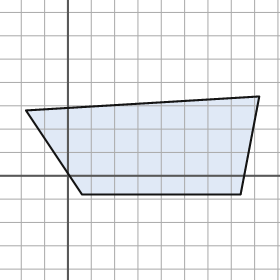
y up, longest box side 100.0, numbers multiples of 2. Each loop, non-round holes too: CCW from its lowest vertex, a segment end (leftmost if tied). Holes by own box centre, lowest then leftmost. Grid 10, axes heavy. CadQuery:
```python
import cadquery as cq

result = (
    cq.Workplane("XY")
    .moveTo(6.0, -8.0)
    .lineTo(74.0, -8.0)
    .lineTo(82.0, 34.0)
    .lineTo(-18.0, 28.0)
    .close()
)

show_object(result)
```